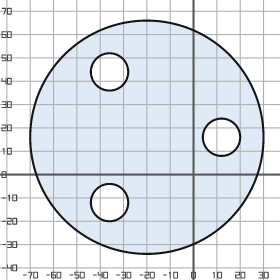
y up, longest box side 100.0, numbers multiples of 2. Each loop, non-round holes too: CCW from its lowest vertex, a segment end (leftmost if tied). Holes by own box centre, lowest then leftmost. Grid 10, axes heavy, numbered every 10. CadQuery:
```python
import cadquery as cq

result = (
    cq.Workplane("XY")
    .moveTo(-20.0, 16.0)
    .circle(50.0)
    .moveTo(-36.0, -12.0)
    .circle(8.0)
    .moveTo(12.0, 16.0)
    .circle(8.0)
    .moveTo(-36.0, 44.0)
    .circle(8.0)
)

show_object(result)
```